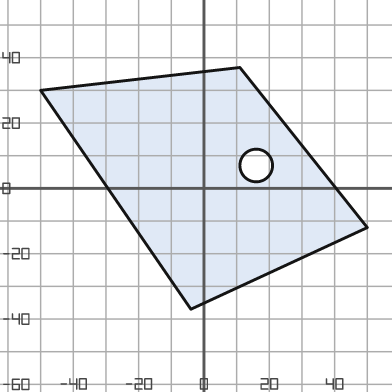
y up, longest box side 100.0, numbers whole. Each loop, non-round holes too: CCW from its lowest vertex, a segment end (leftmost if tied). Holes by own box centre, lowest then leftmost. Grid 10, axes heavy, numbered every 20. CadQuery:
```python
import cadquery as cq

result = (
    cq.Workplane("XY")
    .moveTo(-4.0, -37.0)
    .lineTo(50.0, -12.0)
    .lineTo(11.0, 37.0)
    .lineTo(-50.0, 30.0)
    .close()
    .moveTo(16.0, 7.0)
    .circle(5.0)
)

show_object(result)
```